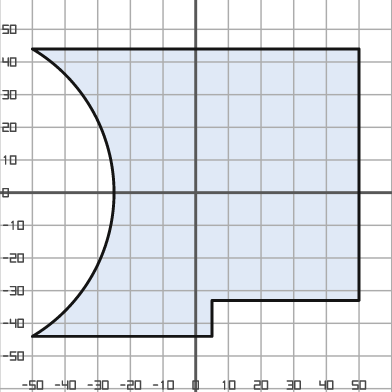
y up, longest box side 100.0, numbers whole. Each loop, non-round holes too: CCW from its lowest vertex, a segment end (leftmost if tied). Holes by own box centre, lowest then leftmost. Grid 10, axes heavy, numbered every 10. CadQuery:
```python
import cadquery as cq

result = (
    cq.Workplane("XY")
    .moveTo(-50.0, -44.0)
    .lineTo(5.0, -44.0)
    .lineTo(5.0, -33.0)
    .lineTo(50.0, -33.0)
    .lineTo(50.0, 44.0)
    .lineTo(-50.0, 44.0)
    .threePointArc((-25.0, 0.0), (-50.0, -44.0))
    .close()
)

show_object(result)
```